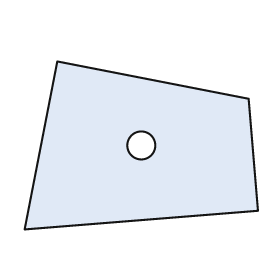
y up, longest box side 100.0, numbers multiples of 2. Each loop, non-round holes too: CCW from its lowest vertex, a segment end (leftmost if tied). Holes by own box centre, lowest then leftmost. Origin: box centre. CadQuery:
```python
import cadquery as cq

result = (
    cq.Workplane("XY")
    .moveTo(-50.0, -36.0)
    .lineTo(50.0, -28.0)
    .lineTo(46.0, 20.0)
    .lineTo(-36.0, 36.0)
    .close()
    .moveTo(0.0, 0.0)
    .circle(6.0)
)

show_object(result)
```